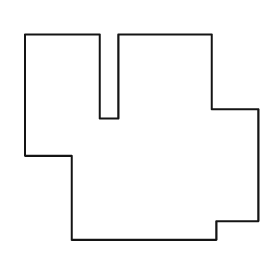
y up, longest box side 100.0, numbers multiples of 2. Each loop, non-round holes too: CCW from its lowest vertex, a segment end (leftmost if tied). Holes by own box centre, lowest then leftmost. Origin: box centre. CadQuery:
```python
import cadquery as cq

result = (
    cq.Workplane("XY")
    .moveTo(-30.0, -44.0)
    .lineTo(32.0, -44.0)
    .lineTo(32.0, -36.0)
    .lineTo(50.0, -36.0)
    .lineTo(50.0, 12.0)
    .lineTo(30.0, 12.0)
    .lineTo(30.0, 44.0)
    .lineTo(-10.0, 44.0)
    .lineTo(-10.0, 8.0)
    .lineTo(-18.0, 8.0)
    .lineTo(-18.0, 44.0)
    .lineTo(-50.0, 44.0)
    .lineTo(-50.0, -8.0)
    .lineTo(-30.0, -8.0)
    .close()
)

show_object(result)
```